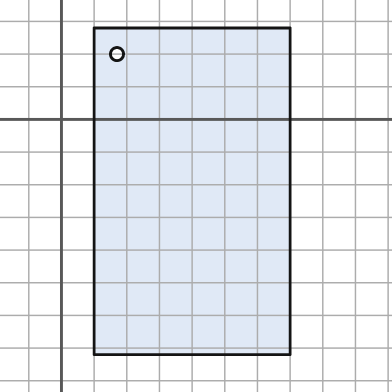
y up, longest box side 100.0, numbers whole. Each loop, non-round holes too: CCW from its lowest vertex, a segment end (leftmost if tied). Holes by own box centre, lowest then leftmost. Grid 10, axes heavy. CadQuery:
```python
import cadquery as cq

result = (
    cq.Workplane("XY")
    .moveTo(10.0, -72.0)
    .lineTo(70.0, -72.0)
    .lineTo(70.0, 28.0)
    .lineTo(10.0, 28.0)
    .close()
    .moveTo(17.0, 20.0)
    .circle(2.0)
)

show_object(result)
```